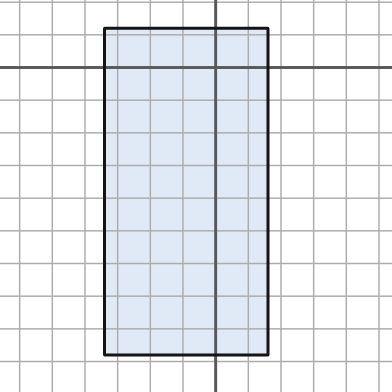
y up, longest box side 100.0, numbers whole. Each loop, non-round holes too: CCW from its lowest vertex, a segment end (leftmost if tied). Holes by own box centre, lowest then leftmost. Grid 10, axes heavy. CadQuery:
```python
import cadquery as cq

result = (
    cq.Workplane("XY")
    .moveTo(-34.0, -88.0)
    .lineTo(16.0, -88.0)
    .lineTo(16.0, 12.0)
    .lineTo(-34.0, 12.0)
    .close()
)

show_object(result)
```